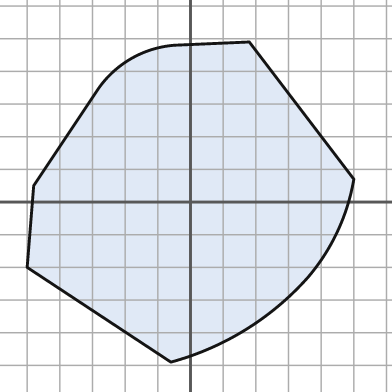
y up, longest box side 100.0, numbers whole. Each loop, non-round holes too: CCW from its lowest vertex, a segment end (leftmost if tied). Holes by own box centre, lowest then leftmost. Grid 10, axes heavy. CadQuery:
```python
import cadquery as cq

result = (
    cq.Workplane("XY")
    .moveTo(-6.0, -49.0)
    .threePointArc((17.0, -39.0), (36.0, -23.0))
    .threePointArc((45.0, -9.0), (50.0, 7.0))
    .lineTo(18.0, 49.0)
    .lineTo(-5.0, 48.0)
    .threePointArc((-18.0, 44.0), (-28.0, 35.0))
    .lineTo(-48.0, 5.0)
    .lineTo(-50.0, -20.0)
    .close()
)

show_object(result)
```